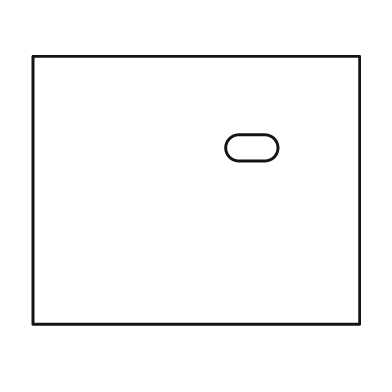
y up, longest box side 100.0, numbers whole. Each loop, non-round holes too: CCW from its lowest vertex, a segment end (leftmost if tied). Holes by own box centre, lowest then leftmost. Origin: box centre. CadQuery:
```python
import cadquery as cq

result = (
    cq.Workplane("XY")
    .moveTo(-50.0, -41.0)
    .lineTo(50.0, -41.0)
    .lineTo(50.0, 41.0)
    .lineTo(-50.0, 41.0)
    .close()
    .moveTo(13.0, 9.0)
    .lineTo(21.0, 9.0)
    .threePointArc((25.0, 13.0), (21.0, 17.0))
    .lineTo(13.0, 17.0)
    .threePointArc((9.0, 13.0), (13.0, 9.0))
    .close()
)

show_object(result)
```